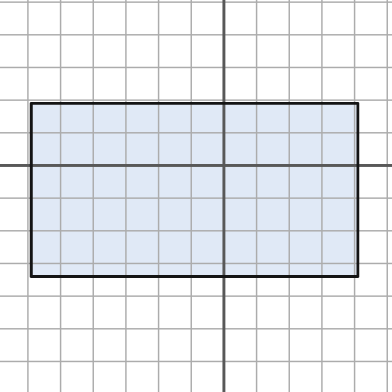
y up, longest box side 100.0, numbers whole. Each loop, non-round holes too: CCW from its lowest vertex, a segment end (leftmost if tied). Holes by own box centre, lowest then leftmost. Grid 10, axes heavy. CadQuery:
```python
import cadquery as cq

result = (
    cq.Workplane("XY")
    .moveTo(-59.0, -34.0)
    .lineTo(41.0, -34.0)
    .lineTo(41.0, 19.0)
    .lineTo(-59.0, 19.0)
    .close()
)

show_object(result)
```